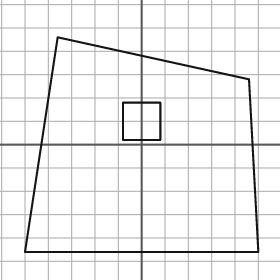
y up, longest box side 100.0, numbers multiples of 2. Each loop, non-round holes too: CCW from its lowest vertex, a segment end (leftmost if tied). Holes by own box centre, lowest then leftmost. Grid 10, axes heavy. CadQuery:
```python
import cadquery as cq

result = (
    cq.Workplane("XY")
    .moveTo(-50.0, -46.0)
    .lineTo(50.0, -46.0)
    .lineTo(46.0, 28.0)
    .lineTo(-36.0, 46.0)
    .close()
    .moveTo(-8.0, 2.0)
    .lineTo(8.0, 2.0)
    .lineTo(8.0, 18.0)
    .lineTo(-8.0, 18.0)
    .close()
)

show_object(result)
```